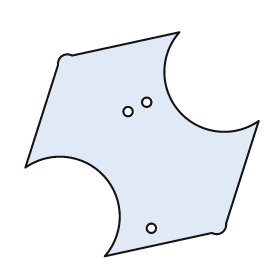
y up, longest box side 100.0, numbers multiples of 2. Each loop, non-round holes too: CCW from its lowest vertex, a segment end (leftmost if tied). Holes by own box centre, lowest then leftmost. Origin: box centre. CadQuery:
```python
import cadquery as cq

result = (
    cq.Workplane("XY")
    .moveTo(-16.0, -48.0)
    .lineTo(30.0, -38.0)
    .threePointArc((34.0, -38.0), (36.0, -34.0))
    .lineTo(50.0, 10.0)
    .threePointArc((16.0, 14.0), (16.0, 48.0))
    .lineTo(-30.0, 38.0)
    .threePointArc((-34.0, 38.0), (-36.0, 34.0))
    .lineTo(-50.0, -10.0)
    .threePointArc((-16.0, -14.0), (-16.0, -48.0))
    .close()
    .moveTo(4.0, -36.0)
    .circle(2.0)
    .moveTo(-6.0, 14.0)
    .circle(2.0)
    .moveTo(2.0, 18.0)
    .circle(2.0)
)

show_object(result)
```